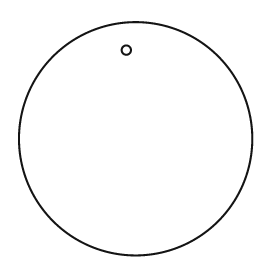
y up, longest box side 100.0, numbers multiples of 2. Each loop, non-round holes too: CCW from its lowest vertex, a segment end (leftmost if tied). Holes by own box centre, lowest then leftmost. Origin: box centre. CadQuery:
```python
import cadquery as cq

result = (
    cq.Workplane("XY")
    .moveTo(0.0, 0.0)
    .circle(50.0)
    .moveTo(-4.0, 38.0)
    .circle(2.0)
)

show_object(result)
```